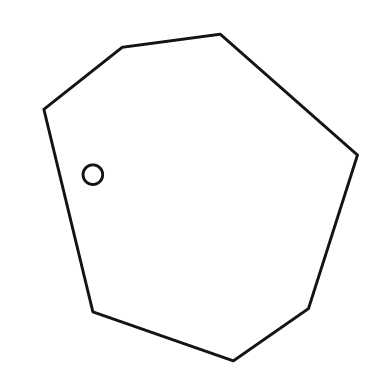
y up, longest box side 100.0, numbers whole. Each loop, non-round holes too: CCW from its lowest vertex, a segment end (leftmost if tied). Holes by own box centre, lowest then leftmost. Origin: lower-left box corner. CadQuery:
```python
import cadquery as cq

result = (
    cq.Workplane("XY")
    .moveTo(58.0, 0.0)
    .lineTo(81.0, 16.0)
    .lineTo(96.0, 63.0)
    .lineTo(54.0, 100.0)
    .lineTo(24.0, 96.0)
    .lineTo(0.0, 77.0)
    .lineTo(15.0, 15.0)
    .close()
    .moveTo(15.0, 57.0)
    .circle(3.0)
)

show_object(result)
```